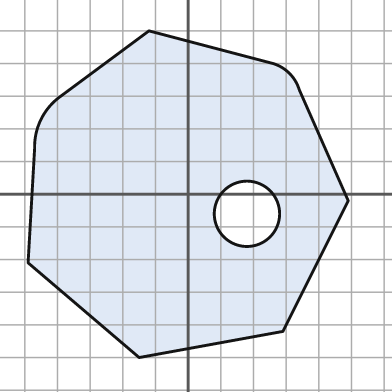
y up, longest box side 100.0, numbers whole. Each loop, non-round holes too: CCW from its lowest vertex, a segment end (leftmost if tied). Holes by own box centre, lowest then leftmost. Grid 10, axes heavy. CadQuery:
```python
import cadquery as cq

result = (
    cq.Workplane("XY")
    .moveTo(-15.0, -50.0)
    .lineTo(29.0, -42.0)
    .lineTo(49.0, -2.0)
    .lineTo(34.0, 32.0)
    .threePointArc((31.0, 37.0), (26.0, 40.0))
    .lineTo(-12.0, 50.0)
    .lineTo(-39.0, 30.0)
    .threePointArc((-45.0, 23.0), (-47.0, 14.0))
    .lineTo(-49.0, -21.0)
    .close()
    .moveTo(18.0, -6.0)
    .circle(10.0)
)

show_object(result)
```